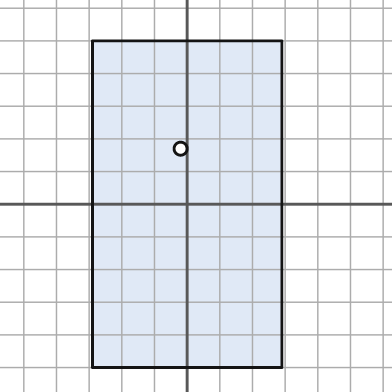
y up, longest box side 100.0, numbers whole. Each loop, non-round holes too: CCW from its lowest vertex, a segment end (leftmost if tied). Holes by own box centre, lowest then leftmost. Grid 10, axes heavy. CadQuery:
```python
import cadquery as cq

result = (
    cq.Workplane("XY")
    .moveTo(-29.0, -50.0)
    .lineTo(29.0, -50.0)
    .lineTo(29.0, 50.0)
    .lineTo(-29.0, 50.0)
    .close()
    .moveTo(-2.0, 17.0)
    .circle(2.0)
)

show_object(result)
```